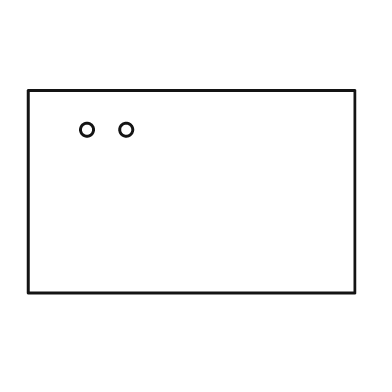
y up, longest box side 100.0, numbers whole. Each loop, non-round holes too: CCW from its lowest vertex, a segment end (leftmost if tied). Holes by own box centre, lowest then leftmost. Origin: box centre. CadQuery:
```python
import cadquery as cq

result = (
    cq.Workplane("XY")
    .moveTo(-50.0, -31.0)
    .lineTo(50.0, -31.0)
    .lineTo(50.0, 31.0)
    .lineTo(-50.0, 31.0)
    .close()
    .moveTo(-32.0, 19.0)
    .circle(2.0)
    .moveTo(-20.0, 19.0)
    .circle(2.0)
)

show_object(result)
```